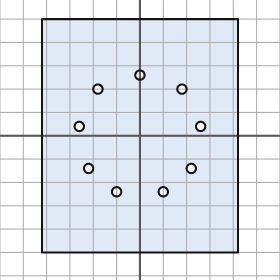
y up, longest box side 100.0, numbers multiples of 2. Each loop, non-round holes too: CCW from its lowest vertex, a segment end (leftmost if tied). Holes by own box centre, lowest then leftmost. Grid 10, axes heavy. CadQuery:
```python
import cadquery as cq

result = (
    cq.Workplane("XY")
    .moveTo(-42.0, -50.0)
    .lineTo(42.0, -50.0)
    .lineTo(42.0, 50.0)
    .lineTo(-42.0, 50.0)
    .close()
    .moveTo(-10.0, -24.0)
    .circle(2.0)
    .moveTo(10.0, -24.0)
    .circle(2.0)
    .moveTo(-22.0, -14.0)
    .circle(2.0)
    .moveTo(22.0, -14.0)
    .circle(2.0)
    .moveTo(-26.0, 4.0)
    .circle(2.0)
    .moveTo(26.0, 4.0)
    .circle(2.0)
    .moveTo(-18.0, 20.0)
    .circle(2.0)
    .moveTo(18.0, 20.0)
    .circle(2.0)
    .moveTo(0.0, 26.0)
    .circle(2.0)
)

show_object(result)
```